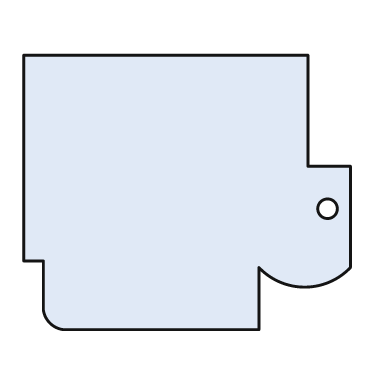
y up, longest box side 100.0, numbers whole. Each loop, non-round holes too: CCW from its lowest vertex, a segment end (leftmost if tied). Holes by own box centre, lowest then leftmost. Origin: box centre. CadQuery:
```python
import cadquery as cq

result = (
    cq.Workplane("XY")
    .moveTo(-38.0, -42.0)
    .lineTo(22.0, -42.0)
    .lineTo(22.0, -23.0)
    .threePointArc((36.0, -29.0), (50.0, -23.0))
    .lineTo(50.0, 8.0)
    .lineTo(37.0, 8.0)
    .lineTo(37.0, 42.0)
    .lineTo(-50.0, 42.0)
    .lineTo(-50.0, -21.0)
    .lineTo(-44.0, -21.0)
    .lineTo(-44.0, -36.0)
    .threePointArc((-42.0, -40.0), (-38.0, -42.0))
    .close()
    .moveTo(43.0, -5.0)
    .circle(3.0)
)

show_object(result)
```